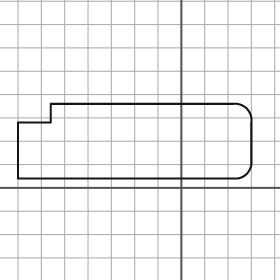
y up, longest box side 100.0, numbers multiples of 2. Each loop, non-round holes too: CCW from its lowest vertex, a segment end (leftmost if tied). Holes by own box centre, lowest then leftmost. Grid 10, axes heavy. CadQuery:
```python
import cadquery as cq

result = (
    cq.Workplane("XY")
    .moveTo(-70.0, 4.0)
    .lineTo(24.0, 4.0)
    .threePointArc((28.0, 6.0), (30.0, 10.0))
    .lineTo(30.0, 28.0)
    .threePointArc((28.0, 34.0), (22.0, 36.0))
    .lineTo(-56.0, 36.0)
    .lineTo(-56.0, 28.0)
    .lineTo(-70.0, 28.0)
    .close()
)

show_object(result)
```